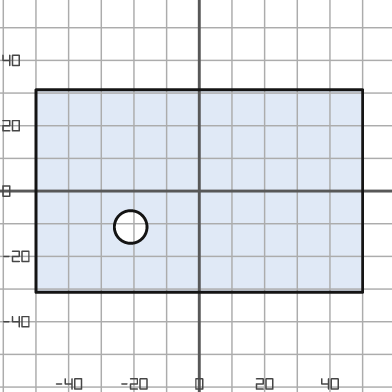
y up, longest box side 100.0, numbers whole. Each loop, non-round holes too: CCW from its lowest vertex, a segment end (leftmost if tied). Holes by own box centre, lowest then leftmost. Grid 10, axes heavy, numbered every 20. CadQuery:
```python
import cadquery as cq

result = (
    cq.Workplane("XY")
    .moveTo(-50.0, -31.0)
    .lineTo(50.0, -31.0)
    .lineTo(50.0, 31.0)
    .lineTo(-50.0, 31.0)
    .close()
    .moveTo(-21.0, -11.0)
    .circle(5.0)
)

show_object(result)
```